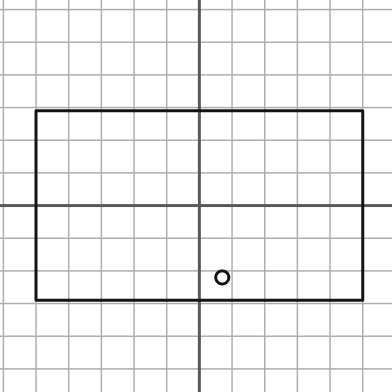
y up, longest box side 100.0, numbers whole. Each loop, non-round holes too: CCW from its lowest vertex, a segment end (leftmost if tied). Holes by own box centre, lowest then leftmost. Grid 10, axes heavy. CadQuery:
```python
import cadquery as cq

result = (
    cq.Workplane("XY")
    .moveTo(-50.0, -29.0)
    .lineTo(50.0, -29.0)
    .lineTo(50.0, 29.0)
    .lineTo(-50.0, 29.0)
    .close()
    .moveTo(7.0, -22.0)
    .circle(2.0)
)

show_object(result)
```